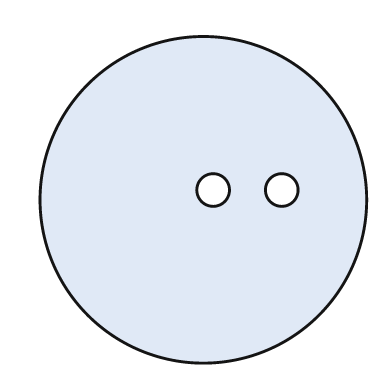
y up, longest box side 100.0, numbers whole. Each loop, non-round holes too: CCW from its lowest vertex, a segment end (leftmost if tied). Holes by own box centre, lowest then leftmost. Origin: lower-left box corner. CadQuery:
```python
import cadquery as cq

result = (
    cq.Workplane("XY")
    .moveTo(50.0, 50.0)
    .circle(50.0)
    .moveTo(53.0, 53.0)
    .circle(5.0)
    .moveTo(74.0, 53.0)
    .circle(5.0)
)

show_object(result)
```